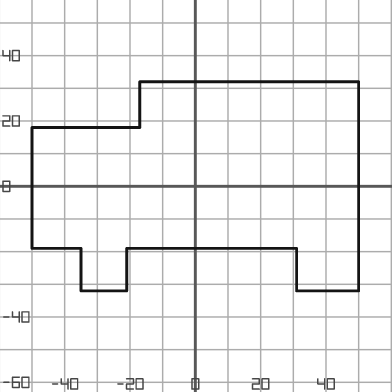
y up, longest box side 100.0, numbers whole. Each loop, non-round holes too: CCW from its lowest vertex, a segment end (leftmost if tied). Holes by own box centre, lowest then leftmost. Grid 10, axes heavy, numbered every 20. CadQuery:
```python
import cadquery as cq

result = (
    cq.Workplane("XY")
    .moveTo(-35.0, -32.0)
    .lineTo(-21.0, -32.0)
    .lineTo(-21.0, -19.0)
    .lineTo(31.0, -19.0)
    .lineTo(31.0, -32.0)
    .lineTo(50.0, -32.0)
    .lineTo(50.0, 32.0)
    .lineTo(-17.0, 32.0)
    .lineTo(-17.0, 18.0)
    .lineTo(-50.0, 18.0)
    .lineTo(-50.0, -19.0)
    .lineTo(-35.0, -19.0)
    .close()
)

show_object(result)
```